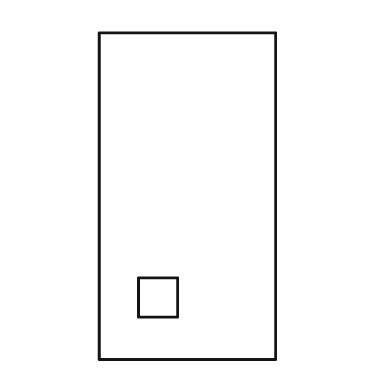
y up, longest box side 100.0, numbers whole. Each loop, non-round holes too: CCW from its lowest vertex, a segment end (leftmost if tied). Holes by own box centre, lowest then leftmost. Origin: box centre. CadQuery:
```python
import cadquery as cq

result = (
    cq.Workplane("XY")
    .moveTo(-27.0, -50.0)
    .lineTo(27.0, -50.0)
    .lineTo(27.0, 50.0)
    .lineTo(-27.0, 50.0)
    .close()
    .moveTo(-15.0, -37.0)
    .lineTo(-3.0, -37.0)
    .lineTo(-3.0, -25.0)
    .lineTo(-15.0, -25.0)
    .close()
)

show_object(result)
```